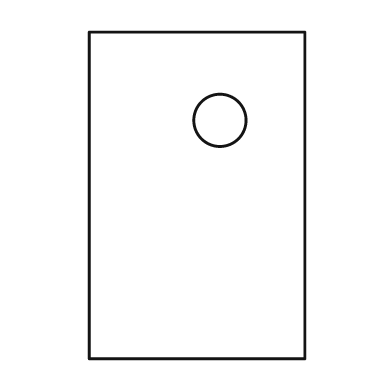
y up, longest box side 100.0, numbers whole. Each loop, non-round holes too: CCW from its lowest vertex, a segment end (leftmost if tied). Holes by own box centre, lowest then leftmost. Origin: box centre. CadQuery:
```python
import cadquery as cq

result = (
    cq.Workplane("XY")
    .moveTo(-33.0, -50.0)
    .lineTo(33.0, -50.0)
    .lineTo(33.0, 50.0)
    .lineTo(-33.0, 50.0)
    .close()
    .moveTo(7.0, 23.0)
    .circle(8.0)
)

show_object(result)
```